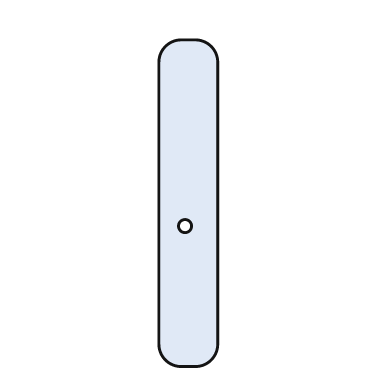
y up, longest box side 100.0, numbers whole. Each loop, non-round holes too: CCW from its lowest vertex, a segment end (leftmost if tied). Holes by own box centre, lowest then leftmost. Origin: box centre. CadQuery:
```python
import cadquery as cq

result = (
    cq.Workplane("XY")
    .moveTo(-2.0, -50.0)
    .lineTo(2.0, -50.0)
    .threePointArc((7.0, -48.0), (9.0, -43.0))
    .lineTo(9.0, 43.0)
    .threePointArc((7.0, 48.0), (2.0, 50.0))
    .lineTo(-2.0, 50.0)
    .threePointArc((-7.0, 48.0), (-9.0, 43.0))
    .lineTo(-9.0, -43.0)
    .threePointArc((-7.0, -48.0), (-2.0, -50.0))
    .close()
    .moveTo(-1.0, -7.0)
    .circle(2.0)
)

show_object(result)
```